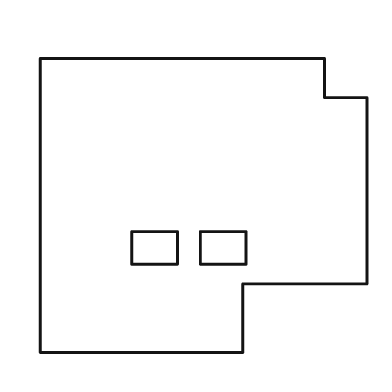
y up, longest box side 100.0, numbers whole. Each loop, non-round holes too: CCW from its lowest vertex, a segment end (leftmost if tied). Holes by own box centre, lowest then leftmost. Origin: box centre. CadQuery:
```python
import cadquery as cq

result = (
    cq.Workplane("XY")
    .moveTo(-50.0, -45.0)
    .lineTo(12.0, -45.0)
    .lineTo(12.0, -24.0)
    .lineTo(50.0, -24.0)
    .lineTo(50.0, 33.0)
    .lineTo(37.0, 33.0)
    .lineTo(37.0, 45.0)
    .lineTo(-50.0, 45.0)
    .close()
    .moveTo(-22.0, -18.0)
    .lineTo(-8.0, -18.0)
    .lineTo(-8.0, -8.0)
    .lineTo(-22.0, -8.0)
    .close()
    .moveTo(-1.0, -18.0)
    .lineTo(13.0, -18.0)
    .lineTo(13.0, -8.0)
    .lineTo(-1.0, -8.0)
    .close()
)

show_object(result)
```